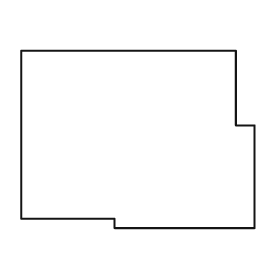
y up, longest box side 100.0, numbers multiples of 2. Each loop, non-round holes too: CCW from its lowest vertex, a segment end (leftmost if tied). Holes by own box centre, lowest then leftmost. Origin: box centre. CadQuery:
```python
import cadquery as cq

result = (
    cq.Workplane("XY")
    .moveTo(-10.0, -38.0)
    .lineTo(50.0, -38.0)
    .lineTo(50.0, 6.0)
    .lineTo(42.0, 6.0)
    .lineTo(42.0, 38.0)
    .lineTo(-50.0, 38.0)
    .lineTo(-50.0, -34.0)
    .lineTo(-10.0, -34.0)
    .close()
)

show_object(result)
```